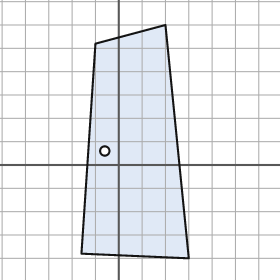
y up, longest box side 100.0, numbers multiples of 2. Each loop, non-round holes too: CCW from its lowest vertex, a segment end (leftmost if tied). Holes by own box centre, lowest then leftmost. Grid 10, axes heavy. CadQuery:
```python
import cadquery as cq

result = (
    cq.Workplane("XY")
    .moveTo(30.0, -40.0)
    .lineTo(20.0, 60.0)
    .lineTo(-10.0, 52.0)
    .lineTo(-16.0, -38.0)
    .close()
    .moveTo(-6.0, 6.0)
    .circle(2.0)
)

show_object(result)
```